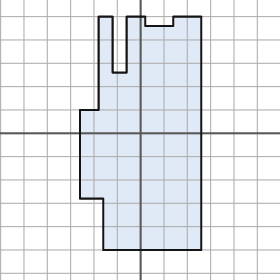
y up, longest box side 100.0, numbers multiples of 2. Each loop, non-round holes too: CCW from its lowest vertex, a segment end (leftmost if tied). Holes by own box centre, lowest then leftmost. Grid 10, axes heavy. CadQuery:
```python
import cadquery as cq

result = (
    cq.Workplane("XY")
    .moveTo(-16.0, -50.0)
    .lineTo(26.0, -50.0)
    .lineTo(26.0, 50.0)
    .lineTo(14.0, 50.0)
    .lineTo(14.0, 46.0)
    .lineTo(2.0, 46.0)
    .lineTo(2.0, 50.0)
    .lineTo(-6.0, 50.0)
    .lineTo(-6.0, 26.0)
    .lineTo(-12.0, 26.0)
    .lineTo(-12.0, 50.0)
    .lineTo(-18.0, 50.0)
    .lineTo(-18.0, 10.0)
    .lineTo(-26.0, 10.0)
    .lineTo(-26.0, -28.0)
    .lineTo(-16.0, -28.0)
    .close()
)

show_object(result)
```